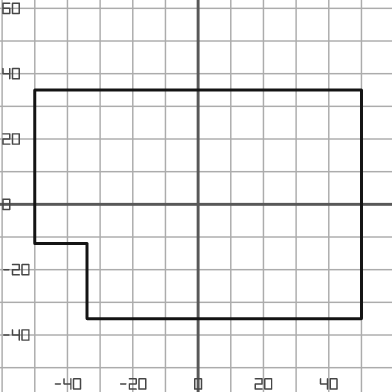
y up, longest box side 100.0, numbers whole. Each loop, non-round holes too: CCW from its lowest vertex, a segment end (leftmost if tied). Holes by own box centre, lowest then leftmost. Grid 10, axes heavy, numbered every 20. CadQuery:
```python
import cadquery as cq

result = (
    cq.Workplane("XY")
    .moveTo(-34.0, -35.0)
    .lineTo(50.0, -35.0)
    .lineTo(50.0, 35.0)
    .lineTo(-50.0, 35.0)
    .lineTo(-50.0, -12.0)
    .lineTo(-34.0, -12.0)
    .close()
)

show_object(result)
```